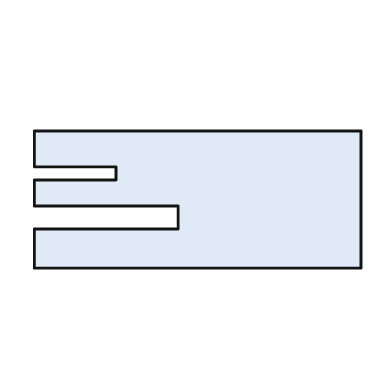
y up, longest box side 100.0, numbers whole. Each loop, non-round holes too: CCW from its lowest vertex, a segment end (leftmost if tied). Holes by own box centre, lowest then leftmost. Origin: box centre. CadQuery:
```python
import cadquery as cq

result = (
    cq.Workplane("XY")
    .moveTo(-50.0, -21.0)
    .lineTo(50.0, -21.0)
    .lineTo(50.0, 21.0)
    .lineTo(-50.0, 21.0)
    .lineTo(-50.0, 10.0)
    .lineTo(-25.0, 10.0)
    .lineTo(-25.0, 6.0)
    .lineTo(-50.0, 6.0)
    .lineTo(-50.0, -2.0)
    .lineTo(-6.0, -2.0)
    .lineTo(-6.0, -9.0)
    .lineTo(-50.0, -9.0)
    .close()
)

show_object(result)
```